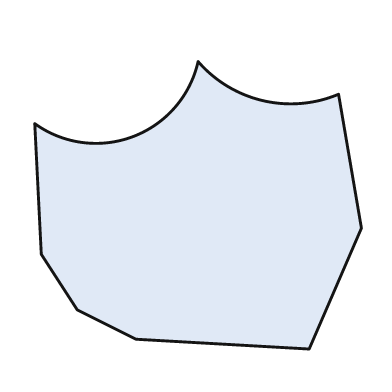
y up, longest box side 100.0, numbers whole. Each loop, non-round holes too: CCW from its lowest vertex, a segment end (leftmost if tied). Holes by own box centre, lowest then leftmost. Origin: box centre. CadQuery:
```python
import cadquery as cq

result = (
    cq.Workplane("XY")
    .moveTo(34.0, -44.0)
    .lineTo(50.0, -7.0)
    .lineTo(43.0, 34.0)
    .threePointArc((20.0, 32.0), (0.0, 44.0))
    .threePointArc((-20.0, 21.0), (-50.0, 25.0))
    .lineTo(-48.0, -15.0)
    .lineTo(-37.0, -32.0)
    .lineTo(-19.0, -41.0)
    .close()
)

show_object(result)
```